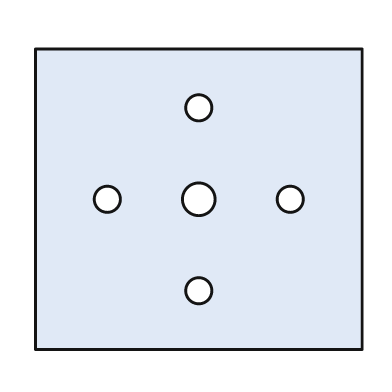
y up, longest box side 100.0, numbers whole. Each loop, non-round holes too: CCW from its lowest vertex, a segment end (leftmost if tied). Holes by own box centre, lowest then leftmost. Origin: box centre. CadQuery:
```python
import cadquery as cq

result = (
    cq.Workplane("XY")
    .moveTo(-50.0, -46.0)
    .lineTo(50.0, -46.0)
    .lineTo(50.0, 46.0)
    .lineTo(-50.0, 46.0)
    .close()
    .moveTo(0.0, -28.0)
    .circle(4.0)
    .moveTo(-28.0, 0.0)
    .circle(4.0)
    .moveTo(0.0, 0.0)
    .circle(5.0)
    .moveTo(28.0, 0.0)
    .circle(4.0)
    .moveTo(0.0, 28.0)
    .circle(4.0)
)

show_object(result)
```